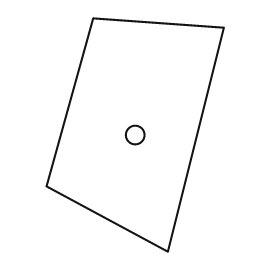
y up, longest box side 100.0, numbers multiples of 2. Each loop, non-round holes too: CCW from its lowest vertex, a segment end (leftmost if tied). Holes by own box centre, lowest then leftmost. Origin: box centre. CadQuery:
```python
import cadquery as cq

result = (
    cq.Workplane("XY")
    .moveTo(14.0, -50.0)
    .lineTo(38.0, 46.0)
    .lineTo(-18.0, 50.0)
    .lineTo(-38.0, -22.0)
    .close()
    .moveTo(0.0, 0.0)
    .circle(4.0)
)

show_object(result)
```